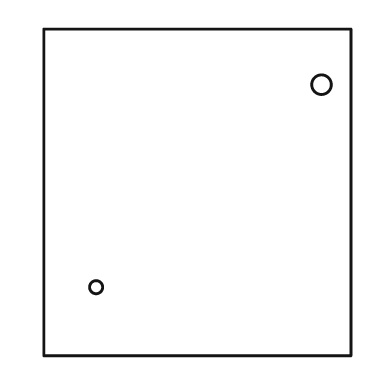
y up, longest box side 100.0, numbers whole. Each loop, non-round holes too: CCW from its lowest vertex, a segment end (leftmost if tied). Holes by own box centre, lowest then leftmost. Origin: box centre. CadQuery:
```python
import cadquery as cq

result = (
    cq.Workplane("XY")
    .moveTo(-47.0, -50.0)
    .lineTo(47.0, -50.0)
    .lineTo(47.0, 50.0)
    .lineTo(-47.0, 50.0)
    .close()
    .moveTo(-31.0, -29.0)
    .circle(2.0)
    .moveTo(38.0, 33.0)
    .circle(3.0)
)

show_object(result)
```